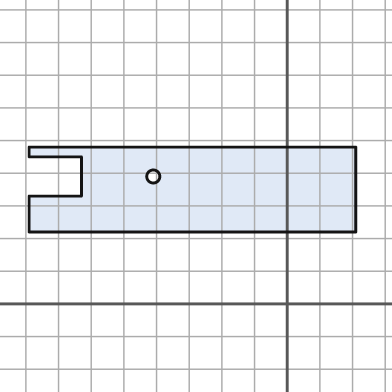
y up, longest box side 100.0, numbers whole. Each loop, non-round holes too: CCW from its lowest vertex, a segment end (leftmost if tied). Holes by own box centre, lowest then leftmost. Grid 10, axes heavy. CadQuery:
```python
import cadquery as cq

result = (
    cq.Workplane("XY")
    .moveTo(-79.0, 22.0)
    .lineTo(21.0, 22.0)
    .lineTo(21.0, 48.0)
    .lineTo(-79.0, 48.0)
    .lineTo(-79.0, 45.0)
    .lineTo(-63.0, 45.0)
    .lineTo(-63.0, 33.0)
    .lineTo(-79.0, 33.0)
    .close()
    .moveTo(-41.0, 39.0)
    .circle(2.0)
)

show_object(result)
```